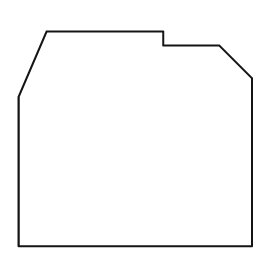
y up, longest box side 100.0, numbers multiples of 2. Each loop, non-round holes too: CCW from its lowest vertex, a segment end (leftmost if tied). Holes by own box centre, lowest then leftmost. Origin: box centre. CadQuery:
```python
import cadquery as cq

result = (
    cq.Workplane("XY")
    .moveTo(-50.0, -46.0)
    .lineTo(50.0, -46.0)
    .lineTo(50.0, 26.0)
    .lineTo(36.0, 40.0)
    .lineTo(12.0, 40.0)
    .lineTo(12.0, 46.0)
    .lineTo(-38.0, 46.0)
    .lineTo(-50.0, 18.0)
    .close()
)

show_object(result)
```